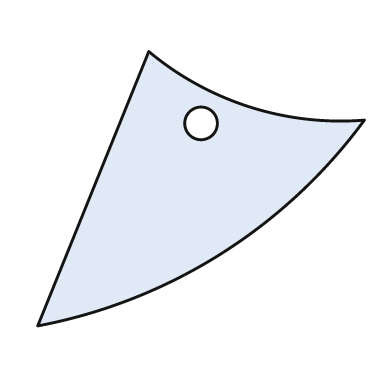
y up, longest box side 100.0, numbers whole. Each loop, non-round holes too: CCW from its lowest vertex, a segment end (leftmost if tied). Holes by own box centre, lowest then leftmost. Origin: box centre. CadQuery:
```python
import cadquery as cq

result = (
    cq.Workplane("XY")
    .moveTo(-50.0, -42.0)
    .threePointArc((6.0, -20.0), (50.0, 21.0))
    .threePointArc((15.0, 25.0), (-16.0, 42.0))
    .close()
    .moveTo(0.0, 20.0)
    .circle(5.0)
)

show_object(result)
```